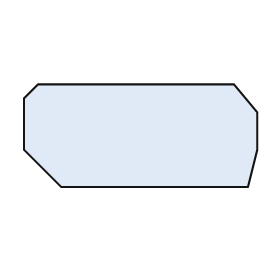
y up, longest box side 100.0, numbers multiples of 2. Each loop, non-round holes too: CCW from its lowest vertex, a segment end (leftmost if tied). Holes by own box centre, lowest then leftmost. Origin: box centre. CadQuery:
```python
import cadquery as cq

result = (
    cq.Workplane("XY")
    .moveTo(-34.0, -22.0)
    .lineTo(46.0, -22.0)
    .lineTo(50.0, -6.0)
    .lineTo(50.0, 10.0)
    .lineTo(40.0, 22.0)
    .lineTo(-44.0, 22.0)
    .lineTo(-50.0, 16.0)
    .lineTo(-50.0, -6.0)
    .close()
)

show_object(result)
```